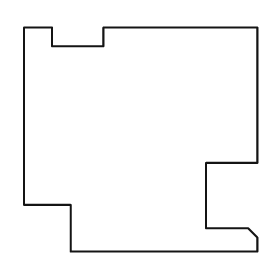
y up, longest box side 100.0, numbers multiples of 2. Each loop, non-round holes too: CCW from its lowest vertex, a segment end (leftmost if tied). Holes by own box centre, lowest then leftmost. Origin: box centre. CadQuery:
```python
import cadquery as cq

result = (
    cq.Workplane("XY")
    .moveTo(-30.0, -48.0)
    .lineTo(50.0, -48.0)
    .lineTo(50.0, -42.0)
    .lineTo(46.0, -38.0)
    .lineTo(28.0, -38.0)
    .lineTo(28.0, -10.0)
    .lineTo(50.0, -10.0)
    .lineTo(50.0, 48.0)
    .lineTo(-16.0, 48.0)
    .lineTo(-16.0, 40.0)
    .lineTo(-38.0, 40.0)
    .lineTo(-38.0, 48.0)
    .lineTo(-50.0, 48.0)
    .lineTo(-50.0, -28.0)
    .lineTo(-30.0, -28.0)
    .close()
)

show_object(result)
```